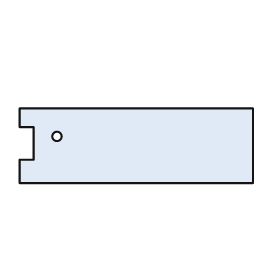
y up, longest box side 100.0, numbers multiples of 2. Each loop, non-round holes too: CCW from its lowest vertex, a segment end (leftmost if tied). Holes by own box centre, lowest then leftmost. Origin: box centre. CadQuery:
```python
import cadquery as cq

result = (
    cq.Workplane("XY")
    .moveTo(-50.0, -16.0)
    .lineTo(50.0, -16.0)
    .lineTo(50.0, 16.0)
    .lineTo(-50.0, 16.0)
    .lineTo(-50.0, 8.0)
    .lineTo(-44.0, 8.0)
    .lineTo(-44.0, -6.0)
    .lineTo(-50.0, -6.0)
    .close()
    .moveTo(-34.0, 4.0)
    .circle(2.0)
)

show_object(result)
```